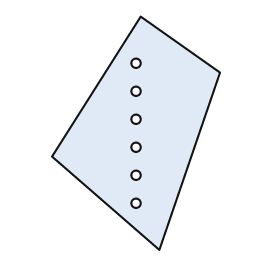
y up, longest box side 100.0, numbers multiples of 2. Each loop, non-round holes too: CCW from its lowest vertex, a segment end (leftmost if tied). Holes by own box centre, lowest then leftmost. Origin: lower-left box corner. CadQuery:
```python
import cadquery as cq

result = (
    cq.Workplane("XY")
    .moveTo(46.0, 0.0)
    .lineTo(72.0, 76.0)
    .lineTo(38.0, 100.0)
    .lineTo(0.0, 40.0)
    .close()
    .moveTo(36.0, 20.0)
    .circle(2.0)
    .moveTo(36.0, 32.0)
    .circle(2.0)
    .moveTo(36.0, 44.0)
    .circle(2.0)
    .moveTo(36.0, 56.0)
    .circle(2.0)
    .moveTo(36.0, 68.0)
    .circle(2.0)
    .moveTo(36.0, 80.0)
    .circle(2.0)
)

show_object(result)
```